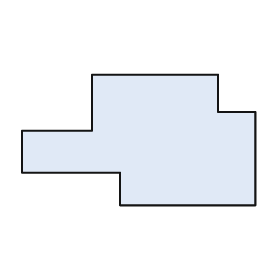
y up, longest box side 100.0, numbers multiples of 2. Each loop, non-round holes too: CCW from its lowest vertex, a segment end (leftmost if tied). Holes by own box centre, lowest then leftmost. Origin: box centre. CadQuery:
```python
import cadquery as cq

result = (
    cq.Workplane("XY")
    .moveTo(-8.0, -28.0)
    .lineTo(50.0, -28.0)
    .lineTo(50.0, 12.0)
    .lineTo(34.0, 12.0)
    .lineTo(34.0, 28.0)
    .lineTo(-20.0, 28.0)
    .lineTo(-20.0, 4.0)
    .lineTo(-50.0, 4.0)
    .lineTo(-50.0, -14.0)
    .lineTo(-8.0, -14.0)
    .close()
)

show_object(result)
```